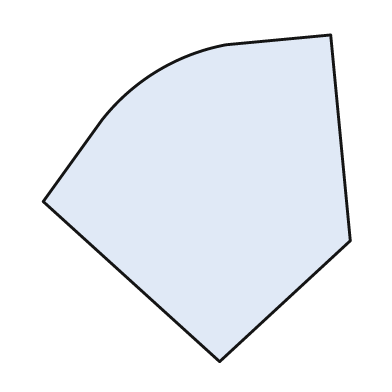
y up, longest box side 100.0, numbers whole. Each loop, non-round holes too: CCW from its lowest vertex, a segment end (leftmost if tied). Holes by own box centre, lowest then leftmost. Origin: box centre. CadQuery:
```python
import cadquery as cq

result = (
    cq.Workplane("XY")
    .moveTo(7.0, -50.0)
    .lineTo(47.0, -13.0)
    .lineTo(41.0, 50.0)
    .lineTo(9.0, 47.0)
    .threePointArc((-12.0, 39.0), (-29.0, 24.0))
    .lineTo(-47.0, -1.0)
    .close()
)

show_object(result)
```